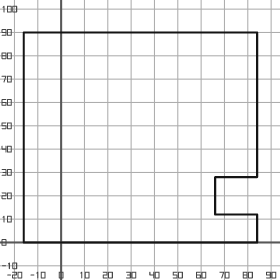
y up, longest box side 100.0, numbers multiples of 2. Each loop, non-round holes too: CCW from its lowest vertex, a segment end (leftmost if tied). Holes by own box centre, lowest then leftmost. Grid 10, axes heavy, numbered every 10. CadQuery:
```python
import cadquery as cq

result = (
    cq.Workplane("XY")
    .moveTo(-16.0, 0.0)
    .lineTo(84.0, 0.0)
    .lineTo(84.0, 12.0)
    .lineTo(66.0, 12.0)
    .lineTo(66.0, 28.0)
    .lineTo(84.0, 28.0)
    .lineTo(84.0, 90.0)
    .lineTo(-16.0, 90.0)
    .close()
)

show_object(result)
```